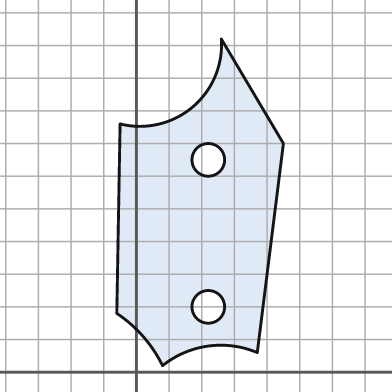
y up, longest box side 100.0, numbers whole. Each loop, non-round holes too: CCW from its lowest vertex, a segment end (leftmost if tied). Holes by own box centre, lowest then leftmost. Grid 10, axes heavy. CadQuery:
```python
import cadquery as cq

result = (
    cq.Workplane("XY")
    .moveTo(8.0, 2.0)
    .threePointArc((22.0, 8.0), (37.0, 6.0))
    .lineTo(45.0, 70.0)
    .lineTo(26.0, 102.0)
    .threePointArc((17.0, 81.0), (-5.0, 76.0))
    .lineTo(-6.0, 18.0)
    .threePointArc((2.0, 11.0), (8.0, 2.0))
    .close()
    .moveTo(22.0, 20.0)
    .circle(5.0)
    .moveTo(22.0, 65.0)
    .circle(5.0)
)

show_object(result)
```